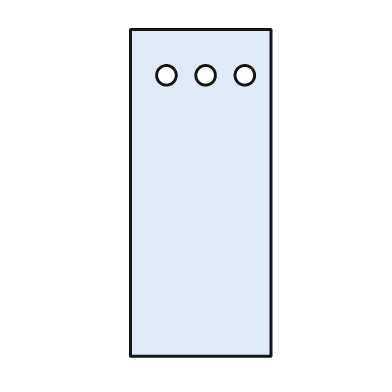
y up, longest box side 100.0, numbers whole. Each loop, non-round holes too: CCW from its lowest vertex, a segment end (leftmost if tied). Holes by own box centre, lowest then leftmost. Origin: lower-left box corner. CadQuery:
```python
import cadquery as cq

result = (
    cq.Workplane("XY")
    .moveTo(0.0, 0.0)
    .lineTo(43.0, 0.0)
    .lineTo(43.0, 100.0)
    .lineTo(0.0, 100.0)
    .close()
    .moveTo(11.0, 86.0)
    .circle(3.0)
    .moveTo(23.0, 86.0)
    .circle(3.0)
    .moveTo(35.0, 86.0)
    .circle(3.0)
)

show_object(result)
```